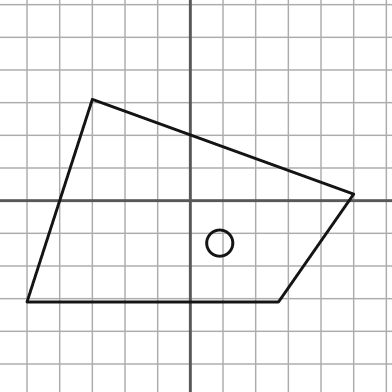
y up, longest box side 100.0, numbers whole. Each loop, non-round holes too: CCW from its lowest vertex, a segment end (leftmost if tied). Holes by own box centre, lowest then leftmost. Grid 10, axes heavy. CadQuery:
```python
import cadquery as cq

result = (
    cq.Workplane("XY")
    .moveTo(-50.0, -31.0)
    .lineTo(27.0, -31.0)
    .lineTo(50.0, 2.0)
    .lineTo(-30.0, 31.0)
    .close()
    .moveTo(9.0, -13.0)
    .circle(4.0)
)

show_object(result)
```